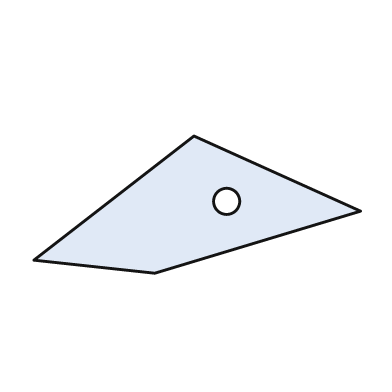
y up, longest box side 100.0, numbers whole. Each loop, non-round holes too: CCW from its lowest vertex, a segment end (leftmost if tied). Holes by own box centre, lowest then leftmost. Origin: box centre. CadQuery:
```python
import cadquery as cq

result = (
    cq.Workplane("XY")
    .moveTo(-13.0, -21.0)
    .lineTo(50.0, -2.0)
    .lineTo(-1.0, 21.0)
    .lineTo(-50.0, -17.0)
    .close()
    .moveTo(9.0, 1.0)
    .circle(4.0)
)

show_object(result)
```